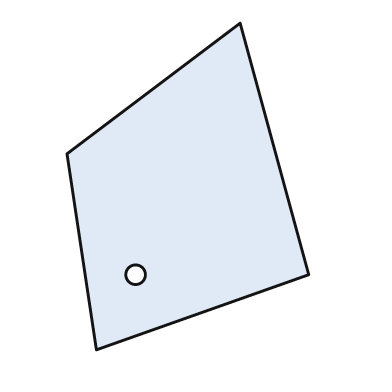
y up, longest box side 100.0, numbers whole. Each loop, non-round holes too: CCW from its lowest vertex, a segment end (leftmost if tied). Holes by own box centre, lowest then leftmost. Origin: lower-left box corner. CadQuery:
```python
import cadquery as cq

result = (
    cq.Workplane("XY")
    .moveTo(9.0, 0.0)
    .lineTo(74.0, 23.0)
    .lineTo(53.0, 100.0)
    .lineTo(0.0, 60.0)
    .close()
    .moveTo(21.0, 23.0)
    .circle(3.0)
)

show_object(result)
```